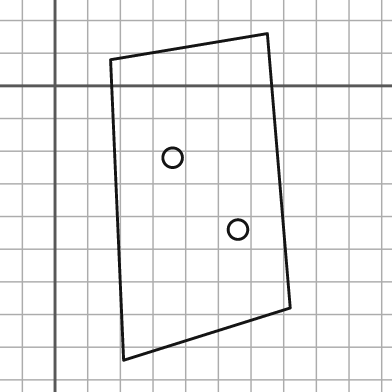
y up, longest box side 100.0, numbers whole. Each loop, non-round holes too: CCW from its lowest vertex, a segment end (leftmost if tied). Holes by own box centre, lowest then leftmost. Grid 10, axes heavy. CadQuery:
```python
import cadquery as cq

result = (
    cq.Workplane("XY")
    .moveTo(21.0, -84.0)
    .lineTo(72.0, -68.0)
    .lineTo(65.0, 16.0)
    .lineTo(17.0, 8.0)
    .close()
    .moveTo(56.0, -44.0)
    .circle(3.0)
    .moveTo(36.0, -22.0)
    .circle(3.0)
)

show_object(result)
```